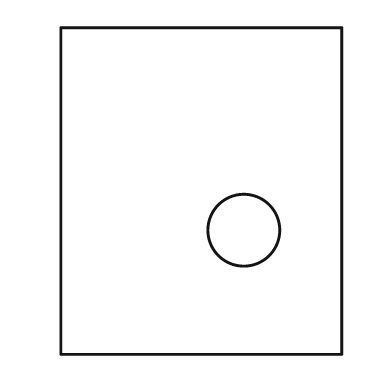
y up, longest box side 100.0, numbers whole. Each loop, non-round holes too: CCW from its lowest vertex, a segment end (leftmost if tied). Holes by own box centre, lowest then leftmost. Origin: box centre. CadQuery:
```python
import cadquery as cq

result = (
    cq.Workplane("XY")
    .moveTo(-43.0, -50.0)
    .lineTo(43.0, -50.0)
    .lineTo(43.0, 50.0)
    .lineTo(-43.0, 50.0)
    .close()
    .moveTo(13.0, -12.0)
    .circle(11.0)
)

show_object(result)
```